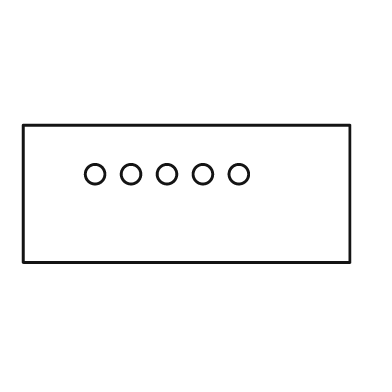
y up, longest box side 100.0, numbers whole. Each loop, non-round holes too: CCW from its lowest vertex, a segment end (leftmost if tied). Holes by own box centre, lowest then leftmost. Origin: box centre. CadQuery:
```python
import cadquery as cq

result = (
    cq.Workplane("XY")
    .moveTo(-50.0, -21.0)
    .lineTo(50.0, -21.0)
    .lineTo(50.0, 21.0)
    .lineTo(-50.0, 21.0)
    .close()
    .moveTo(-28.0, 6.0)
    .circle(3.0)
    .moveTo(-17.0, 6.0)
    .circle(3.0)
    .moveTo(-6.0, 6.0)
    .circle(3.0)
    .moveTo(5.0, 6.0)
    .circle(3.0)
    .moveTo(16.0, 6.0)
    .circle(3.0)
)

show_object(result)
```